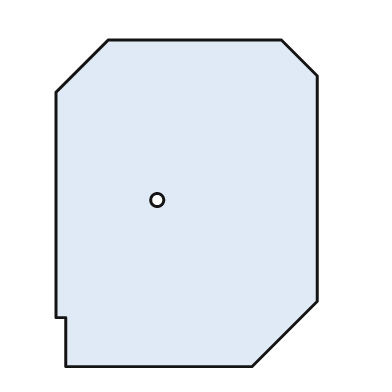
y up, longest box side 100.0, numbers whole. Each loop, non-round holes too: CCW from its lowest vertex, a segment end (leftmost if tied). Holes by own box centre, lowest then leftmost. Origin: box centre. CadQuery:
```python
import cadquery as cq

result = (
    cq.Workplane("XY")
    .moveTo(-37.0, -50.0)
    .lineTo(20.0, -50.0)
    .lineTo(40.0, -30.0)
    .lineTo(40.0, 39.0)
    .lineTo(29.0, 50.0)
    .lineTo(-24.0, 50.0)
    .lineTo(-40.0, 34.0)
    .lineTo(-40.0, -35.0)
    .lineTo(-37.0, -35.0)
    .close()
    .moveTo(-9.0, 1.0)
    .circle(2.0)
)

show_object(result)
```